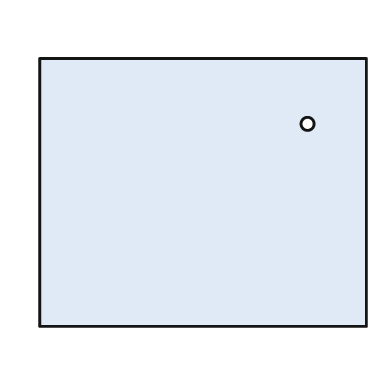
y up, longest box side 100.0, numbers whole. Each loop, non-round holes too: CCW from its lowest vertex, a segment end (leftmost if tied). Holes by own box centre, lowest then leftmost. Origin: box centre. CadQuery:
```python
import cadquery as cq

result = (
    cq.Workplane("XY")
    .moveTo(-50.0, -41.0)
    .lineTo(50.0, -41.0)
    .lineTo(50.0, 41.0)
    .lineTo(-50.0, 41.0)
    .close()
    .moveTo(32.0, 21.0)
    .circle(2.0)
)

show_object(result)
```